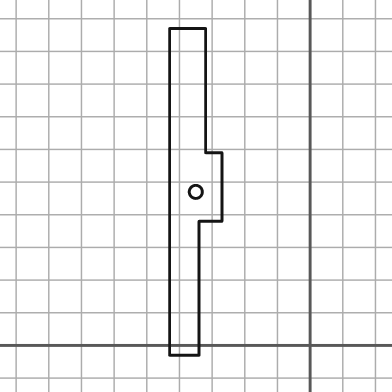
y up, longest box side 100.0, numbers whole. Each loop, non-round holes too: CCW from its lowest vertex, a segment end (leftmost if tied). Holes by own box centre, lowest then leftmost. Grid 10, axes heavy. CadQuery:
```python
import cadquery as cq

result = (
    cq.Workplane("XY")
    .moveTo(-43.0, -3.0)
    .lineTo(-34.0, -3.0)
    .lineTo(-34.0, 38.0)
    .lineTo(-27.0, 38.0)
    .lineTo(-27.0, 59.0)
    .lineTo(-32.0, 59.0)
    .lineTo(-32.0, 97.0)
    .lineTo(-43.0, 97.0)
    .close()
    .moveTo(-35.0, 47.0)
    .circle(2.0)
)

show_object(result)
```